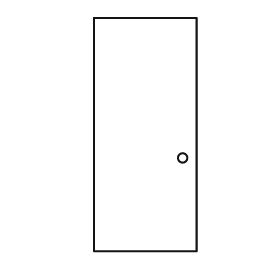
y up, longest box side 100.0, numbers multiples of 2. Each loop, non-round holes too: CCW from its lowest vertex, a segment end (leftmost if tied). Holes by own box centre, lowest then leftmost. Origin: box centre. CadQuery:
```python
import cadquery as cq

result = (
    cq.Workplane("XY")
    .moveTo(-22.0, -50.0)
    .lineTo(22.0, -50.0)
    .lineTo(22.0, 50.0)
    .lineTo(-22.0, 50.0)
    .close()
    .moveTo(16.0, -10.0)
    .circle(2.0)
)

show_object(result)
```